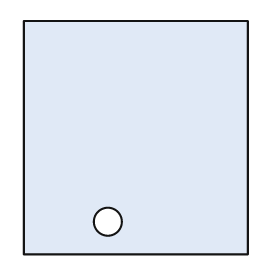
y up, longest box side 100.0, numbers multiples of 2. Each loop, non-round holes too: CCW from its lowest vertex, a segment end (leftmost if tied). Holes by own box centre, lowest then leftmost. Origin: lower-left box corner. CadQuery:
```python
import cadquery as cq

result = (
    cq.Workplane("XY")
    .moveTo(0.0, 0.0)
    .lineTo(96.0, 0.0)
    .lineTo(96.0, 100.0)
    .lineTo(0.0, 100.0)
    .close()
    .moveTo(36.0, 14.0)
    .circle(6.0)
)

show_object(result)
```